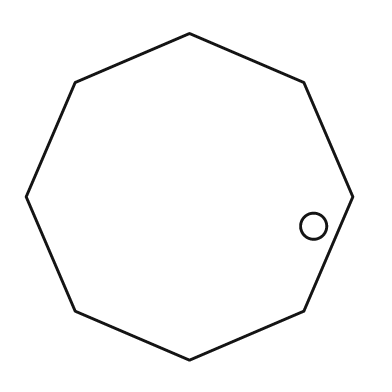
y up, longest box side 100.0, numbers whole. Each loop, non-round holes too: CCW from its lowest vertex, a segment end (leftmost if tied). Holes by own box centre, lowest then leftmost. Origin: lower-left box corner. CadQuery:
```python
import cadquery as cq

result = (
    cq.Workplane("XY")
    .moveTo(50.0, 0.0)
    .lineTo(85.0, 15.0)
    .lineTo(100.0, 50.0)
    .lineTo(85.0, 85.0)
    .lineTo(50.0, 100.0)
    .lineTo(15.0, 85.0)
    .lineTo(0.0, 50.0)
    .lineTo(15.0, 15.0)
    .close()
    .moveTo(88.0, 41.0)
    .circle(4.0)
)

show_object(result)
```